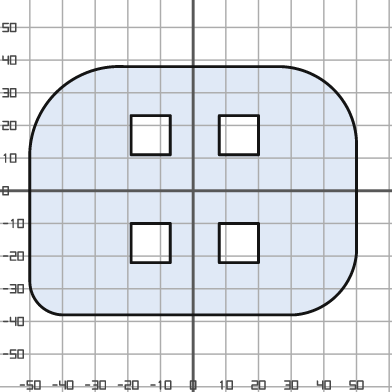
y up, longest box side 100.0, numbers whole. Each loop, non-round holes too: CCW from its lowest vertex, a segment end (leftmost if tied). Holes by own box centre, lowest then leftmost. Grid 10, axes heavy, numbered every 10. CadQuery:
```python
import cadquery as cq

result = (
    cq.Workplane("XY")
    .moveTo(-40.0, -38.0)
    .lineTo(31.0, -38.0)
    .threePointArc((44.0, -32.0), (50.0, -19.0))
    .lineTo(50.0, 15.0)
    .threePointArc((43.0, 31.0), (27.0, 38.0))
    .lineTo(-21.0, 38.0)
    .threePointArc((-42.0, 30.0), (-50.0, 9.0))
    .lineTo(-50.0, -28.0)
    .threePointArc((-47.0, -35.0), (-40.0, -38.0))
    .close()
    .moveTo(-19.0, -22.0)
    .lineTo(-7.0, -22.0)
    .lineTo(-7.0, -10.0)
    .lineTo(-19.0, -10.0)
    .close()
    .moveTo(8.0, -22.0)
    .lineTo(20.0, -22.0)
    .lineTo(20.0, -10.0)
    .lineTo(8.0, -10.0)
    .close()
    .moveTo(-19.0, 11.0)
    .lineTo(-7.0, 11.0)
    .lineTo(-7.0, 23.0)
    .lineTo(-19.0, 23.0)
    .close()
    .moveTo(8.0, 11.0)
    .lineTo(20.0, 11.0)
    .lineTo(20.0, 23.0)
    .lineTo(8.0, 23.0)
    .close()
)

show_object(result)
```